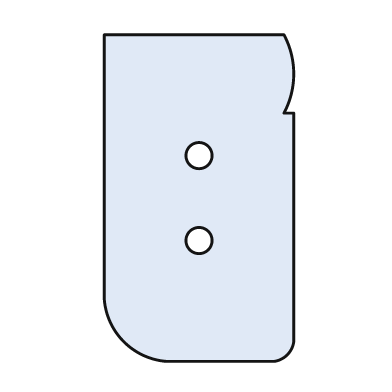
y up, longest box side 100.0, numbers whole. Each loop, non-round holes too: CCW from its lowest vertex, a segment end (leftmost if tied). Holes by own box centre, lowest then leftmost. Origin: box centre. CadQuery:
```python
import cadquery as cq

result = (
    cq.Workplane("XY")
    .moveTo(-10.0, -50.0)
    .lineTo(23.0, -50.0)
    .threePointArc((27.0, -48.0), (29.0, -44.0))
    .lineTo(29.0, 26.0)
    .lineTo(26.0, 26.0)
    .threePointArc((29.0, 38.0), (26.0, 50.0))
    .lineTo(-29.0, 50.0)
    .lineTo(-29.0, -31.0)
    .threePointArc((-23.0, -44.0), (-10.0, -50.0))
    .close()
    .moveTo(0.0, -13.0)
    .circle(4.0)
    .moveTo(0.0, 13.0)
    .circle(4.0)
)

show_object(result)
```